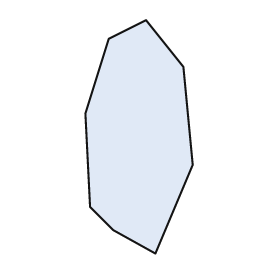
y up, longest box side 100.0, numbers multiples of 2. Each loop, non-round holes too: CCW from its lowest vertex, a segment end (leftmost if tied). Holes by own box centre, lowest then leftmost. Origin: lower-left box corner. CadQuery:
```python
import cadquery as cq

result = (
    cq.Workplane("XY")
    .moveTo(30.0, 0.0)
    .lineTo(46.0, 38.0)
    .lineTo(42.0, 80.0)
    .lineTo(26.0, 100.0)
    .lineTo(10.0, 92.0)
    .lineTo(0.0, 60.0)
    .lineTo(2.0, 20.0)
    .lineTo(12.0, 10.0)
    .close()
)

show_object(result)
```